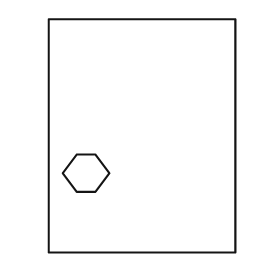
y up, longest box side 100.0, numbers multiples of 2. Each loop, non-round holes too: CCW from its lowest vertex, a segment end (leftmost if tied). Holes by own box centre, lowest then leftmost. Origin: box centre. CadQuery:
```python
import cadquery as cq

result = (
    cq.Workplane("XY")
    .moveTo(-40.0, -50.0)
    .lineTo(40.0, -50.0)
    .lineTo(40.0, 50.0)
    .lineTo(-40.0, 50.0)
    .close()
    .moveTo(-28.0, -24.0)
    .lineTo(-20.0, -24.0)
    .lineTo(-14.0, -16.0)
    .lineTo(-20.0, -8.0)
    .lineTo(-28.0, -8.0)
    .lineTo(-34.0, -16.0)
    .close()
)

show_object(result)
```